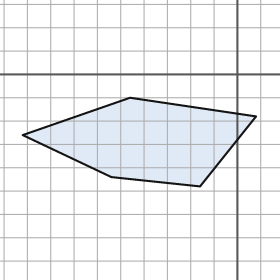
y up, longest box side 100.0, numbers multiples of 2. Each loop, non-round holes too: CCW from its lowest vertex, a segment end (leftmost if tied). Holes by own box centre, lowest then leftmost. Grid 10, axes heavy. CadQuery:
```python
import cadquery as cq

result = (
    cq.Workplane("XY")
    .moveTo(-16.0, -48.0)
    .lineTo(8.0, -18.0)
    .lineTo(-46.0, -10.0)
    .lineTo(-92.0, -26.0)
    .lineTo(-54.0, -44.0)
    .close()
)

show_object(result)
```